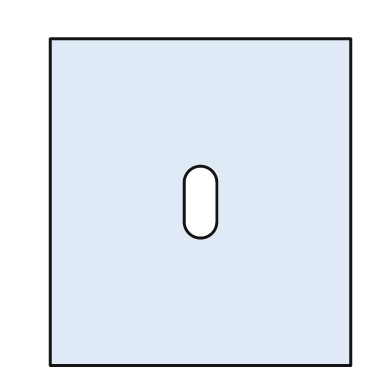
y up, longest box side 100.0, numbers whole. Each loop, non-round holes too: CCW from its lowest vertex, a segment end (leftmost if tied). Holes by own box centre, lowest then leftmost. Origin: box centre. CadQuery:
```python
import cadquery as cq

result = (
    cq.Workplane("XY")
    .moveTo(-46.0, -50.0)
    .lineTo(46.0, -50.0)
    .lineTo(46.0, 50.0)
    .lineTo(-46.0, 50.0)
    .close()
    .moveTo(-5.0, -6.0)
    .threePointArc((0.0, -11.0), (5.0, -6.0))
    .lineTo(5.0, 6.0)
    .threePointArc((0.0, 11.0), (-5.0, 6.0))
    .close()
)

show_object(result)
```